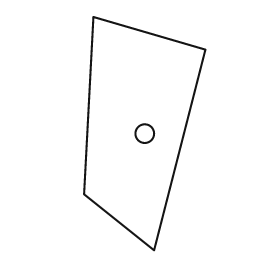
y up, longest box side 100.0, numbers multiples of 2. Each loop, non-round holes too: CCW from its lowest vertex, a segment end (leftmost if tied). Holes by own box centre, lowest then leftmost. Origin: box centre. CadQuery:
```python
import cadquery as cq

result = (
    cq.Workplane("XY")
    .moveTo(4.0, -50.0)
    .lineTo(26.0, 36.0)
    .lineTo(-22.0, 50.0)
    .lineTo(-26.0, -26.0)
    .close()
    .moveTo(0.0, 0.0)
    .circle(4.0)
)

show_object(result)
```